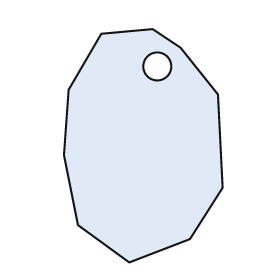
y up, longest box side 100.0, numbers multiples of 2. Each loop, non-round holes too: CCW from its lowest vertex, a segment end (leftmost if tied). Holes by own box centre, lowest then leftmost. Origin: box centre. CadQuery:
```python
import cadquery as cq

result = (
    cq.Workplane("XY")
    .moveTo(-6.0, -50.0)
    .lineTo(20.0, -40.0)
    .lineTo(34.0, -18.0)
    .lineTo(32.0, 22.0)
    .lineTo(16.0, 42.0)
    .lineTo(4.0, 50.0)
    .lineTo(-18.0, 48.0)
    .lineTo(-32.0, 24.0)
    .lineTo(-34.0, -4.0)
    .lineTo(-28.0, -34.0)
    .close()
    .moveTo(6.0, 34.0)
    .circle(6.0)
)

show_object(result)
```